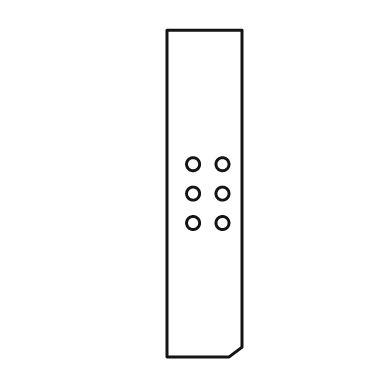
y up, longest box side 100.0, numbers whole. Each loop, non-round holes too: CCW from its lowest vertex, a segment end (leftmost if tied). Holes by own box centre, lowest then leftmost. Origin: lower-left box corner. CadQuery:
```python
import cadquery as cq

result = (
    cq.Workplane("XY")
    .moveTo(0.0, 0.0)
    .lineTo(19.0, 0.0)
    .lineTo(23.0, 3.0)
    .lineTo(23.0, 100.0)
    .lineTo(0.0, 100.0)
    .close()
    .moveTo(8.0, 41.0)
    .circle(2.0)
    .moveTo(17.0, 41.0)
    .circle(2.0)
    .moveTo(8.0, 50.0)
    .circle(2.0)
    .moveTo(17.0, 50.0)
    .circle(2.0)
    .moveTo(8.0, 59.0)
    .circle(2.0)
    .moveTo(17.0, 59.0)
    .circle(2.0)
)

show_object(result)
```